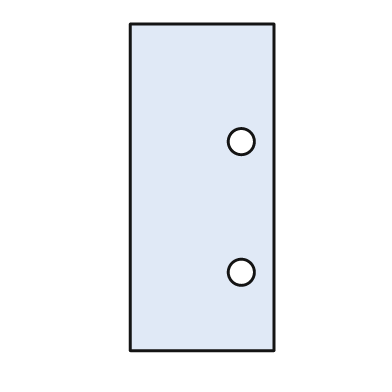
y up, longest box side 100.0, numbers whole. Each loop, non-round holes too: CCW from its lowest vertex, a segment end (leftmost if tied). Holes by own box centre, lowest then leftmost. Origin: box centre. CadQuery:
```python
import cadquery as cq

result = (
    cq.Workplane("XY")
    .moveTo(-22.0, -50.0)
    .lineTo(22.0, -50.0)
    .lineTo(22.0, 50.0)
    .lineTo(-22.0, 50.0)
    .close()
    .moveTo(12.0, -26.0)
    .circle(4.0)
    .moveTo(12.0, 14.0)
    .circle(4.0)
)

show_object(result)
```